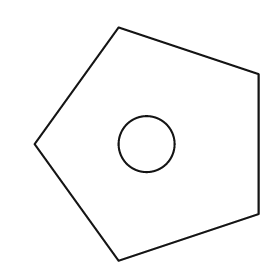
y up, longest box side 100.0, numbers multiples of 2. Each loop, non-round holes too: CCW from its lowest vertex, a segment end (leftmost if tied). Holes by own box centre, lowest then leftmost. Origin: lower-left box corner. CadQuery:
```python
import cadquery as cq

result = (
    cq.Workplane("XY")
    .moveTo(36.0, 0.0)
    .lineTo(96.0, 20.0)
    .lineTo(96.0, 80.0)
    .lineTo(36.0, 100.0)
    .lineTo(0.0, 50.0)
    .close()
    .moveTo(48.0, 50.0)
    .circle(12.0)
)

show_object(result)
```